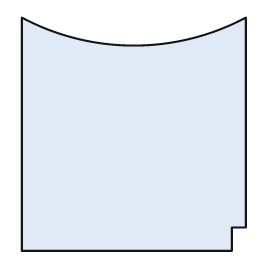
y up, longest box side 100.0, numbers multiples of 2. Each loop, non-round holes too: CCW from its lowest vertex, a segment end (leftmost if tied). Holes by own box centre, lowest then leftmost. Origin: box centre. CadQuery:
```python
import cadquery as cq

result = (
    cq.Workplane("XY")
    .moveTo(-48.0, -50.0)
    .lineTo(42.0, -50.0)
    .lineTo(42.0, -40.0)
    .lineTo(48.0, -40.0)
    .lineTo(48.0, 50.0)
    .threePointArc((0.0, 38.0), (-48.0, 50.0))
    .close()
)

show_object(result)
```